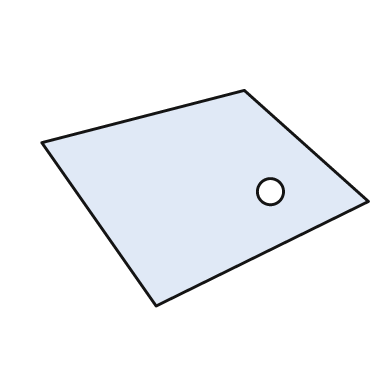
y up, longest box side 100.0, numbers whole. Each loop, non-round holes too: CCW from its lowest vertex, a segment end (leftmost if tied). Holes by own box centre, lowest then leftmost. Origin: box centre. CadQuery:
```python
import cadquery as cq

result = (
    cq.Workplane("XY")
    .moveTo(-15.0, -33.0)
    .lineTo(50.0, -1.0)
    .lineTo(12.0, 33.0)
    .lineTo(-50.0, 17.0)
    .close()
    .moveTo(20.0, 2.0)
    .circle(4.0)
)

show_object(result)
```